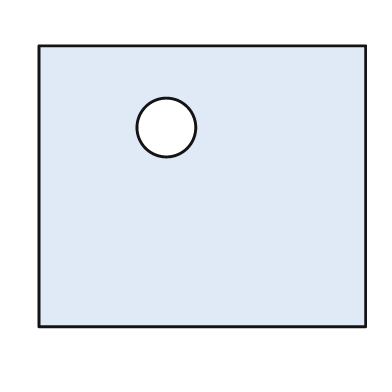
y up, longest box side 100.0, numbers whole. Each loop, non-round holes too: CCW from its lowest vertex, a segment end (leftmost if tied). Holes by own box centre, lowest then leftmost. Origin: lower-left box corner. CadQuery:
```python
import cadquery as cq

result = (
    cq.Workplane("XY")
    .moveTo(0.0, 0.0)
    .lineTo(100.0, 0.0)
    .lineTo(100.0, 86.0)
    .lineTo(0.0, 86.0)
    .close()
    .moveTo(39.0, 61.0)
    .circle(9.0)
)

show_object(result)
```